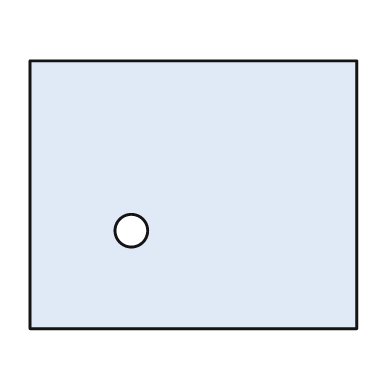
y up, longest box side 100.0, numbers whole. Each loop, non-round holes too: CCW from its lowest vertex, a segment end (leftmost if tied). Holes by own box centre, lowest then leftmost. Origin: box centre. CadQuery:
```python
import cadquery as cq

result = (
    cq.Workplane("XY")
    .moveTo(-50.0, -41.0)
    .lineTo(50.0, -41.0)
    .lineTo(50.0, 41.0)
    .lineTo(-50.0, 41.0)
    .close()
    .moveTo(-19.0, -11.0)
    .circle(5.0)
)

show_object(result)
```